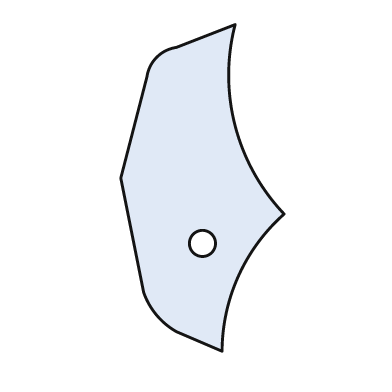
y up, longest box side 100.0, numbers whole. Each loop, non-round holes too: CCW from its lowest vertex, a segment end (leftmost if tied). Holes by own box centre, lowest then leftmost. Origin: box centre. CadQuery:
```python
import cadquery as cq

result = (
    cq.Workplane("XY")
    .moveTo(6.0, -50.0)
    .threePointArc((11.0, -27.0), (25.0, -8.0))
    .threePointArc((10.0, 19.0), (10.0, 50.0))
    .lineTo(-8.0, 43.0)
    .threePointArc((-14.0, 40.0), (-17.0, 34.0))
    .lineTo(-25.0, 3.0)
    .lineTo(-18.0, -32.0)
    .threePointArc((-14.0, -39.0), (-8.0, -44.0))
    .close()
    .moveTo(0.0, -17.0)
    .circle(4.0)
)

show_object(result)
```